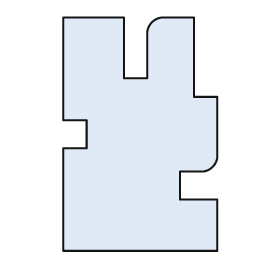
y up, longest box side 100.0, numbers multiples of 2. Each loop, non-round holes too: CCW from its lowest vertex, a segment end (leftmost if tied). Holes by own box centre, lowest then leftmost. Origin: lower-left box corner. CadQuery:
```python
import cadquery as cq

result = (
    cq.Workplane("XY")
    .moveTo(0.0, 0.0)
    .lineTo(66.0, 0.0)
    .lineTo(66.0, 22.0)
    .lineTo(50.0, 22.0)
    .lineTo(50.0, 34.0)
    .lineTo(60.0, 34.0)
    .threePointArc((64.0, 36.0), (66.0, 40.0))
    .lineTo(66.0, 66.0)
    .lineTo(56.0, 66.0)
    .lineTo(56.0, 100.0)
    .lineTo(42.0, 100.0)
    .threePointArc((38.0, 98.0), (36.0, 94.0))
    .lineTo(36.0, 74.0)
    .lineTo(26.0, 74.0)
    .lineTo(26.0, 100.0)
    .lineTo(0.0, 100.0)
    .lineTo(0.0, 56.0)
    .lineTo(10.0, 56.0)
    .lineTo(10.0, 44.0)
    .lineTo(0.0, 44.0)
    .close()
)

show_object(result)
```